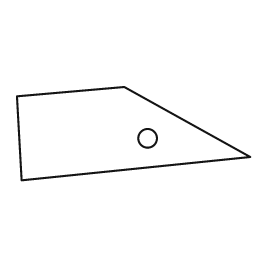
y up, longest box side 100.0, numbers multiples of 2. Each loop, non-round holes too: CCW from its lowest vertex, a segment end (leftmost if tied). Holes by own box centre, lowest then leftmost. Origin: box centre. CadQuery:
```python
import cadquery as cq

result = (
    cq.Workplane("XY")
    .moveTo(-48.0, -20.0)
    .lineTo(50.0, -10.0)
    .lineTo(-4.0, 20.0)
    .lineTo(-50.0, 16.0)
    .close()
    .moveTo(6.0, -2.0)
    .circle(4.0)
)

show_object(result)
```